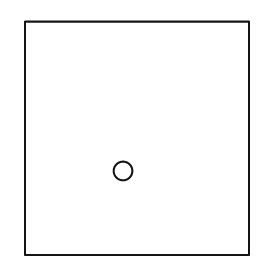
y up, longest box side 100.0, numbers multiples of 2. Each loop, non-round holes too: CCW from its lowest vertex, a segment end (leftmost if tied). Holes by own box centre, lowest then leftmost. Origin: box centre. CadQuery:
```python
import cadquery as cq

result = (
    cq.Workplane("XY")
    .moveTo(-48.0, -50.0)
    .lineTo(48.0, -50.0)
    .lineTo(48.0, 50.0)
    .lineTo(-48.0, 50.0)
    .close()
    .moveTo(-6.0, -14.0)
    .circle(4.0)
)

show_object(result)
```